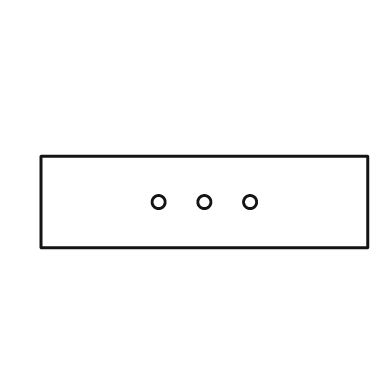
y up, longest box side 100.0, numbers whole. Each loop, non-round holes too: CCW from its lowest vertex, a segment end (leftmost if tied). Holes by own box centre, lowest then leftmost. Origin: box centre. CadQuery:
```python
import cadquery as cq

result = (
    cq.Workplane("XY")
    .moveTo(-50.0, -14.0)
    .lineTo(50.0, -14.0)
    .lineTo(50.0, 14.0)
    .lineTo(-50.0, 14.0)
    .close()
    .moveTo(-14.0, 0.0)
    .circle(2.0)
    .moveTo(0.0, 0.0)
    .circle(2.0)
    .moveTo(14.0, 0.0)
    .circle(2.0)
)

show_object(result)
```